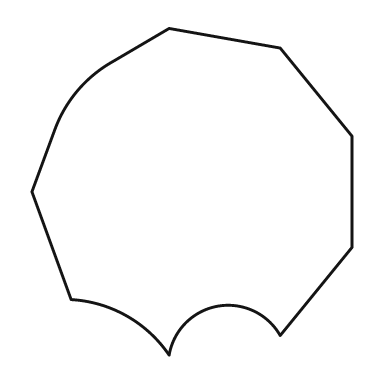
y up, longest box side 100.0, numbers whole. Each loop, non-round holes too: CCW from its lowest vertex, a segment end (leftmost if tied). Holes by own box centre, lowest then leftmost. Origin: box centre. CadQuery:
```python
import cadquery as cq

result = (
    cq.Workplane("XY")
    .moveTo(-7.0, -50.0)
    .threePointArc((8.0, -35.0), (27.0, -44.0))
    .lineTo(49.0, -17.0)
    .lineTo(49.0, 17.0)
    .lineTo(27.0, 44.0)
    .lineTo(-7.0, 50.0)
    .lineTo(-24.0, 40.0)
    .threePointArc((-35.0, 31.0), (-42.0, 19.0))
    .lineTo(-49.0, 0.0)
    .lineTo(-37.0, -33.0)
    .threePointArc((-20.0, -38.0), (-7.0, -50.0))
    .close()
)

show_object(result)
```